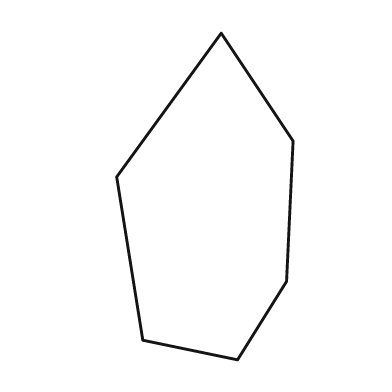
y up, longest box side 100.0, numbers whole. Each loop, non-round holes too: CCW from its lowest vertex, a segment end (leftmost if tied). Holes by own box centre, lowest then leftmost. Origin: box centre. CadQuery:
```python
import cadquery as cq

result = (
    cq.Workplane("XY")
    .moveTo(10.0, -50.0)
    .lineTo(25.0, -26.0)
    .lineTo(27.0, 17.0)
    .lineTo(5.0, 50.0)
    .lineTo(-27.0, 6.0)
    .lineTo(-19.0, -44.0)
    .close()
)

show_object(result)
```